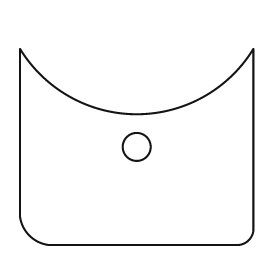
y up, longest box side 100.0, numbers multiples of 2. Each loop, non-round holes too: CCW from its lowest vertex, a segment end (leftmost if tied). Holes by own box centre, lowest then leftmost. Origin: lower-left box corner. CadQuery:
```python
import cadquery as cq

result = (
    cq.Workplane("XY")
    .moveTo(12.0, 0.0)
    .lineTo(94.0, 0.0)
    .threePointArc((98.0, 2.0), (100.0, 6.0))
    .lineTo(100.0, 84.0)
    .threePointArc((50.0, 56.0), (0.0, 84.0))
    .lineTo(0.0, 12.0)
    .threePointArc((4.0, 4.0), (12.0, 0.0))
    .close()
    .moveTo(50.0, 42.0)
    .circle(6.0)
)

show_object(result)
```